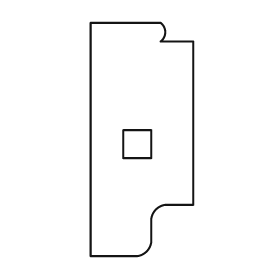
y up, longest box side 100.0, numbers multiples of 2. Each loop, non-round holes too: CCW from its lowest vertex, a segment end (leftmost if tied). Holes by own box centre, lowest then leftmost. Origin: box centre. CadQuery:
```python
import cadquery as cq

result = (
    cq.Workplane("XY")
    .moveTo(-22.0, -50.0)
    .lineTo(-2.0, -50.0)
    .threePointArc((2.0, -48.0), (4.0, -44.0))
    .lineTo(4.0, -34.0)
    .threePointArc((6.0, -30.0), (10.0, -28.0))
    .lineTo(22.0, -28.0)
    .lineTo(22.0, 42.0)
    .lineTo(8.0, 42.0)
    .threePointArc((10.0, 46.0), (8.0, 50.0))
    .lineTo(-22.0, 50.0)
    .close()
    .moveTo(-8.0, -8.0)
    .lineTo(4.0, -8.0)
    .lineTo(4.0, 4.0)
    .lineTo(-8.0, 4.0)
    .close()
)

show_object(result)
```